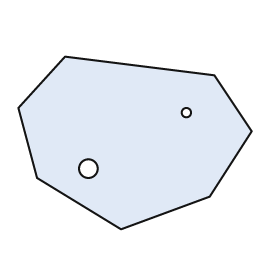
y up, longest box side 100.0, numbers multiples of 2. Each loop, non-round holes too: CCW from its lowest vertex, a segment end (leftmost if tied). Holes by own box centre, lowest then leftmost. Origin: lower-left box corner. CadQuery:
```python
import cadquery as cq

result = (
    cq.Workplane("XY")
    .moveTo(44.0, 0.0)
    .lineTo(82.0, 14.0)
    .lineTo(100.0, 42.0)
    .lineTo(84.0, 66.0)
    .lineTo(20.0, 74.0)
    .lineTo(0.0, 52.0)
    .lineTo(8.0, 22.0)
    .close()
    .moveTo(30.0, 26.0)
    .circle(4.0)
    .moveTo(72.0, 50.0)
    .circle(2.0)
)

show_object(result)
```